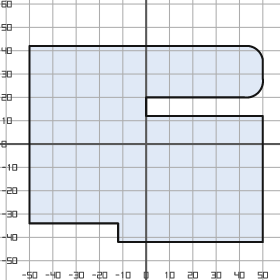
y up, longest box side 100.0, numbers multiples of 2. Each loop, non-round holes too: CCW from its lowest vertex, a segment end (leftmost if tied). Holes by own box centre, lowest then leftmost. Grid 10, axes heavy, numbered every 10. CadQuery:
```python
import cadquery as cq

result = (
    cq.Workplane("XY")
    .moveTo(-12.0, -42.0)
    .lineTo(50.0, -42.0)
    .lineTo(50.0, 12.0)
    .lineTo(0.0, 12.0)
    .lineTo(0.0, 20.0)
    .lineTo(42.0, 20.0)
    .threePointArc((48.0, 22.0), (50.0, 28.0))
    .lineTo(50.0, 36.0)
    .threePointArc((48.0, 40.0), (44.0, 42.0))
    .lineTo(-50.0, 42.0)
    .lineTo(-50.0, -34.0)
    .lineTo(-12.0, -34.0)
    .close()
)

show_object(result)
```